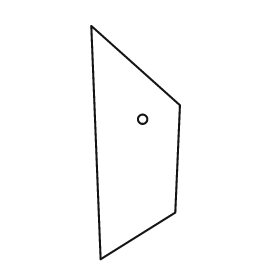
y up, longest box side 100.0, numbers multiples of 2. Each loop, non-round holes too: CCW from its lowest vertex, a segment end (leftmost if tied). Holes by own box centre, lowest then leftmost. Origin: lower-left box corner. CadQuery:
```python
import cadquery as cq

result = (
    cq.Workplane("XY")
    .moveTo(4.0, 0.0)
    .lineTo(36.0, 20.0)
    .lineTo(38.0, 66.0)
    .lineTo(0.0, 100.0)
    .close()
    .moveTo(22.0, 60.0)
    .circle(2.0)
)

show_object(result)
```